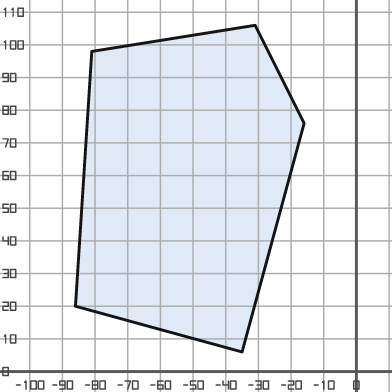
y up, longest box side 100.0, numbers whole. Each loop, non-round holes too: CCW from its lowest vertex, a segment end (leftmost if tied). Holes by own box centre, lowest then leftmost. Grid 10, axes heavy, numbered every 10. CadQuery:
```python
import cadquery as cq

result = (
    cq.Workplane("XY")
    .moveTo(-35.0, 6.0)
    .lineTo(-16.0, 76.0)
    .lineTo(-31.0, 106.0)
    .lineTo(-81.0, 98.0)
    .lineTo(-86.0, 20.0)
    .close()
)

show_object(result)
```